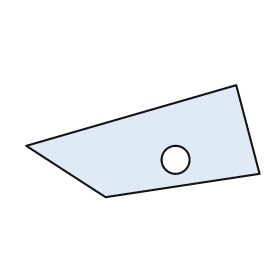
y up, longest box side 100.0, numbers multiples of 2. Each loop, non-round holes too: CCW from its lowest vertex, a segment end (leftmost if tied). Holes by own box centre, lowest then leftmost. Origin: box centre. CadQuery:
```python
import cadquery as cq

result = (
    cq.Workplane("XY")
    .moveTo(-16.0, -24.0)
    .lineTo(50.0, -14.0)
    .lineTo(40.0, 24.0)
    .lineTo(-50.0, -2.0)
    .close()
    .moveTo(14.0, -8.0)
    .circle(6.0)
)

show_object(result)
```